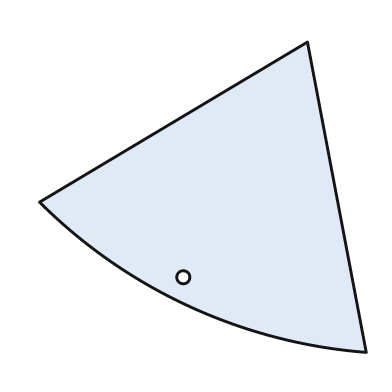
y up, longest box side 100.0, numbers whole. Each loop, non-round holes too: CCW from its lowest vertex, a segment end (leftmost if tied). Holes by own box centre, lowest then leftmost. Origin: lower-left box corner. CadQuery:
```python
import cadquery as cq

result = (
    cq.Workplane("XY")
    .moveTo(100.0, 0.0)
    .lineTo(82.0, 95.0)
    .lineTo(0.0, 46.0)
    .threePointArc((46.0, 14.0), (100.0, 0.0))
    .close()
    .moveTo(44.0, 23.0)
    .circle(2.0)
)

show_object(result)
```